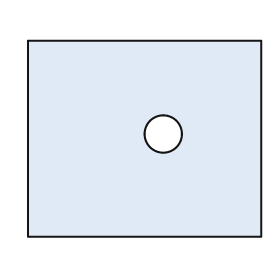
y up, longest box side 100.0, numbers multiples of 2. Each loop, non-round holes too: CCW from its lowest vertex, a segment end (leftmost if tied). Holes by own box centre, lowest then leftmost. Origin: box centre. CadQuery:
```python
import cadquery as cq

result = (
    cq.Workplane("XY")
    .moveTo(-50.0, -42.0)
    .lineTo(50.0, -42.0)
    .lineTo(50.0, 42.0)
    .lineTo(-50.0, 42.0)
    .close()
    .moveTo(8.0, 2.0)
    .circle(8.0)
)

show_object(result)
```